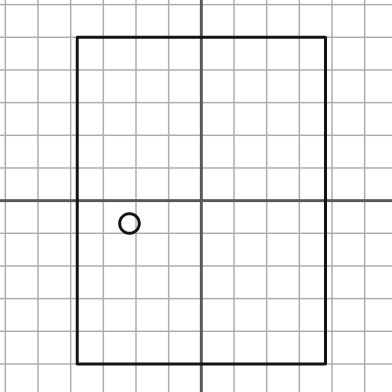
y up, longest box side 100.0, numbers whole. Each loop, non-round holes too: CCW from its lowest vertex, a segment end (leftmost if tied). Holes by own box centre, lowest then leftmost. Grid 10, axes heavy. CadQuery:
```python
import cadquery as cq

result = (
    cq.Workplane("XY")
    .moveTo(-38.0, -50.0)
    .lineTo(38.0, -50.0)
    .lineTo(38.0, 50.0)
    .lineTo(-38.0, 50.0)
    .close()
    .moveTo(-22.0, -7.0)
    .circle(3.0)
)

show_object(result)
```